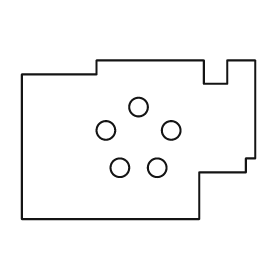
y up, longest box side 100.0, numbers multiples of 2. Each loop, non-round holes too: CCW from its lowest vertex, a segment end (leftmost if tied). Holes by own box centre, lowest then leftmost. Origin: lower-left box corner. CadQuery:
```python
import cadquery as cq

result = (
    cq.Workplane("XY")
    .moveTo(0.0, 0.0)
    .lineTo(76.0, 0.0)
    .lineTo(76.0, 20.0)
    .lineTo(96.0, 20.0)
    .lineTo(96.0, 26.0)
    .lineTo(100.0, 26.0)
    .lineTo(100.0, 68.0)
    .lineTo(88.0, 68.0)
    .lineTo(88.0, 58.0)
    .lineTo(78.0, 58.0)
    .lineTo(78.0, 68.0)
    .lineTo(32.0, 68.0)
    .lineTo(32.0, 62.0)
    .lineTo(0.0, 62.0)
    .close()
    .moveTo(42.0, 22.0)
    .circle(4.0)
    .moveTo(58.0, 22.0)
    .circle(4.0)
    .moveTo(36.0, 38.0)
    .circle(4.0)
    .moveTo(64.0, 38.0)
    .circle(4.0)
    .moveTo(50.0, 48.0)
    .circle(4.0)
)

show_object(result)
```